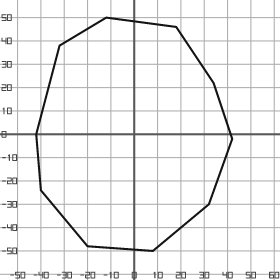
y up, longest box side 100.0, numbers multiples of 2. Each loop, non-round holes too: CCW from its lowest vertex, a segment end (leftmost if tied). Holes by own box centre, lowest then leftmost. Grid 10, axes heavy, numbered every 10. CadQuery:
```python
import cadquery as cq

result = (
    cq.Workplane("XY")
    .moveTo(8.0, -50.0)
    .lineTo(32.0, -30.0)
    .lineTo(42.0, -2.0)
    .lineTo(34.0, 22.0)
    .lineTo(18.0, 46.0)
    .lineTo(-12.0, 50.0)
    .lineTo(-32.0, 38.0)
    .lineTo(-42.0, 0.0)
    .lineTo(-40.0, -24.0)
    .lineTo(-20.0, -48.0)
    .close()
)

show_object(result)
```